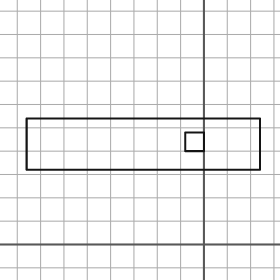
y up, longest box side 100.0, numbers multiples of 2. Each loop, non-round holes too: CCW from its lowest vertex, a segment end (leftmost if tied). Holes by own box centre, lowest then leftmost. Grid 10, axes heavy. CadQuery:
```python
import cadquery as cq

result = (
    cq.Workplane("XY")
    .moveTo(-76.0, 32.0)
    .lineTo(24.0, 32.0)
    .lineTo(24.0, 54.0)
    .lineTo(-76.0, 54.0)
    .close()
    .moveTo(-8.0, 40.0)
    .lineTo(0.0, 40.0)
    .lineTo(0.0, 48.0)
    .lineTo(-8.0, 48.0)
    .close()
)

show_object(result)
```